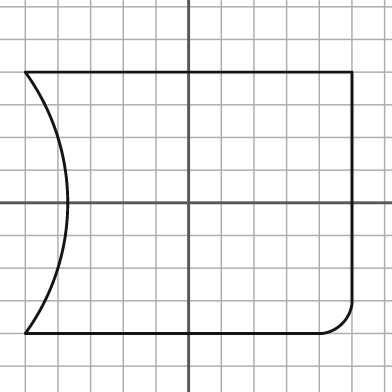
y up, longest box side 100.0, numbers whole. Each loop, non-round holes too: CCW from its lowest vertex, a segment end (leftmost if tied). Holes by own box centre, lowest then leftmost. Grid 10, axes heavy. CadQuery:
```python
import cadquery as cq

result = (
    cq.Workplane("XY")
    .moveTo(-50.0, -40.0)
    .lineTo(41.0, -40.0)
    .threePointArc((47.0, -37.0), (50.0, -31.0))
    .lineTo(50.0, 40.0)
    .lineTo(-50.0, 40.0)
    .threePointArc((-37.0, 0.0), (-50.0, -40.0))
    .close()
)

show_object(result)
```